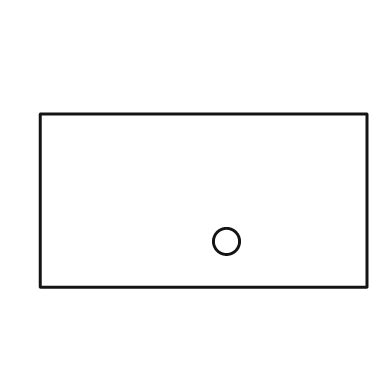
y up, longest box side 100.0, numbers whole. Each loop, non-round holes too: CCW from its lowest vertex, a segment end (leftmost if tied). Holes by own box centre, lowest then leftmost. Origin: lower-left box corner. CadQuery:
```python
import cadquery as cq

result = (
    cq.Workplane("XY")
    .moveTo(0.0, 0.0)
    .lineTo(100.0, 0.0)
    .lineTo(100.0, 53.0)
    .lineTo(0.0, 53.0)
    .close()
    .moveTo(57.0, 14.0)
    .circle(4.0)
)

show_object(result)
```